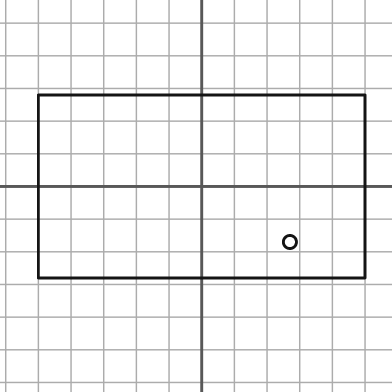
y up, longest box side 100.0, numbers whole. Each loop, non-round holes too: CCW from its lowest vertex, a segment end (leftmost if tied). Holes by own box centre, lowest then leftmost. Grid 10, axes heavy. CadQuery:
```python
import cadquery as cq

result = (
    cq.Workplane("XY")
    .moveTo(-50.0, -28.0)
    .lineTo(50.0, -28.0)
    .lineTo(50.0, 28.0)
    .lineTo(-50.0, 28.0)
    .close()
    .moveTo(27.0, -17.0)
    .circle(2.0)
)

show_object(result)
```